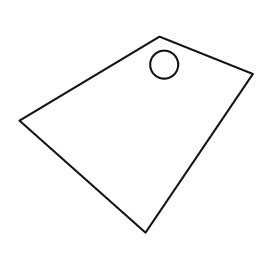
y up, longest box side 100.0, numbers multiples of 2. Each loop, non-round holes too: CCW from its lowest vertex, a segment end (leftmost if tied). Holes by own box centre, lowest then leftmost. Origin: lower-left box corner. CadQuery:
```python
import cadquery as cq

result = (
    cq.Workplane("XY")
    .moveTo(54.0, 0.0)
    .lineTo(100.0, 68.0)
    .lineTo(60.0, 84.0)
    .lineTo(0.0, 48.0)
    .close()
    .moveTo(62.0, 72.0)
    .circle(6.0)
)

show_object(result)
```